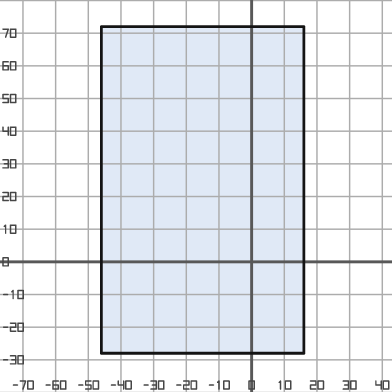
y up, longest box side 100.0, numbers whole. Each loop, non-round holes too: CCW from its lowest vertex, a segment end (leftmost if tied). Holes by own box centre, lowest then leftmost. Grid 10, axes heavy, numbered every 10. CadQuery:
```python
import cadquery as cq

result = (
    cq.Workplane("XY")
    .moveTo(-46.0, -28.0)
    .lineTo(16.0, -28.0)
    .lineTo(16.0, 72.0)
    .lineTo(-46.0, 72.0)
    .close()
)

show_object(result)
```